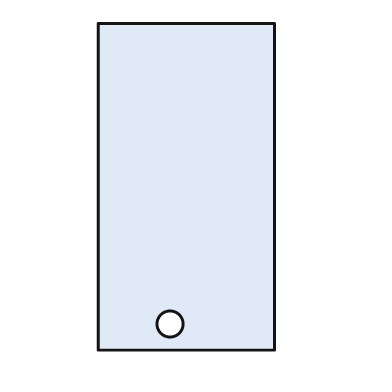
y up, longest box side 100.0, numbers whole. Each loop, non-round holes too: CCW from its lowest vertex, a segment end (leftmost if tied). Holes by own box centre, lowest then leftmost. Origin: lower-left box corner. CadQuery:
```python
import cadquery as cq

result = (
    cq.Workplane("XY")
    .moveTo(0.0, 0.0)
    .lineTo(54.0, 0.0)
    .lineTo(54.0, 100.0)
    .lineTo(0.0, 100.0)
    .close()
    .moveTo(22.0, 8.0)
    .circle(4.0)
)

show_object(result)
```